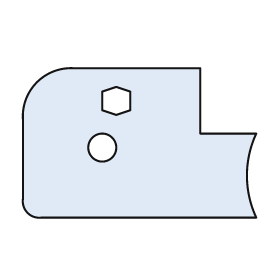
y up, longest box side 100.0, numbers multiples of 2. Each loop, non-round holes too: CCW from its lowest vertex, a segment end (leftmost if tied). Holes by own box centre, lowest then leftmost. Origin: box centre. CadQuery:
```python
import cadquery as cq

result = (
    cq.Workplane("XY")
    .moveTo(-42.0, -32.0)
    .lineTo(50.0, -32.0)
    .threePointArc((46.0, -14.0), (50.0, 4.0))
    .lineTo(26.0, 4.0)
    .lineTo(26.0, 32.0)
    .lineTo(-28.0, 32.0)
    .threePointArc((-44.0, 26.0), (-50.0, 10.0))
    .lineTo(-50.0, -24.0)
    .threePointArc((-48.0, -30.0), (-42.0, -32.0))
    .close()
    .moveTo(-16.0, -2.0)
    .circle(6.0)
    .moveTo(-10.0, 12.0)
    .lineTo(-4.0, 14.0)
    .lineTo(-4.0, 22.0)
    .lineTo(-10.0, 24.0)
    .lineTo(-16.0, 22.0)
    .lineTo(-16.0, 14.0)
    .close()
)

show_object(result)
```